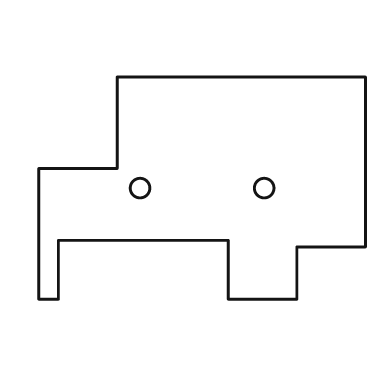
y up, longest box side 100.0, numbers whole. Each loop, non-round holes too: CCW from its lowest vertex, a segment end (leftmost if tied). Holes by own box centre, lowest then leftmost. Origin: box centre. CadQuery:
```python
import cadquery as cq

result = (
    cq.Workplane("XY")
    .moveTo(-50.0, -34.0)
    .lineTo(-44.0, -34.0)
    .lineTo(-44.0, -16.0)
    .lineTo(8.0, -16.0)
    .lineTo(8.0, -34.0)
    .lineTo(29.0, -34.0)
    .lineTo(29.0, -18.0)
    .lineTo(50.0, -18.0)
    .lineTo(50.0, 34.0)
    .lineTo(-26.0, 34.0)
    .lineTo(-26.0, 6.0)
    .lineTo(-50.0, 6.0)
    .close()
    .moveTo(-19.0, 0.0)
    .circle(3.0)
    .moveTo(19.0, 0.0)
    .circle(3.0)
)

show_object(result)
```